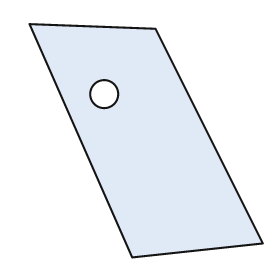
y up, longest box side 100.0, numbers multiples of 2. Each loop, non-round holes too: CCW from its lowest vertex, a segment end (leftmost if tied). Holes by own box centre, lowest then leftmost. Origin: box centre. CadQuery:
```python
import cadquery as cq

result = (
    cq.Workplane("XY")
    .moveTo(-6.0, -50.0)
    .lineTo(50.0, -44.0)
    .lineTo(4.0, 48.0)
    .lineTo(-50.0, 50.0)
    .close()
    .moveTo(-18.0, 20.0)
    .circle(6.0)
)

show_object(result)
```